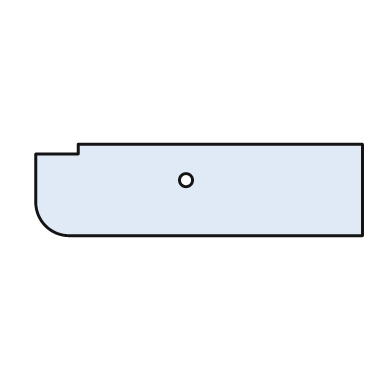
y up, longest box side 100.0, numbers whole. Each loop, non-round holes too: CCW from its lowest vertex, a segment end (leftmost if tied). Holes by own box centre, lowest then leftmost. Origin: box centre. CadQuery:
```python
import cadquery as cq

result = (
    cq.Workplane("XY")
    .moveTo(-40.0, -14.0)
    .lineTo(50.0, -14.0)
    .lineTo(50.0, 14.0)
    .lineTo(-37.0, 14.0)
    .lineTo(-37.0, 11.0)
    .lineTo(-50.0, 11.0)
    .lineTo(-50.0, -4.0)
    .threePointArc((-47.0, -11.0), (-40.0, -14.0))
    .close()
    .moveTo(-4.0, 3.0)
    .circle(2.0)
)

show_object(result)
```